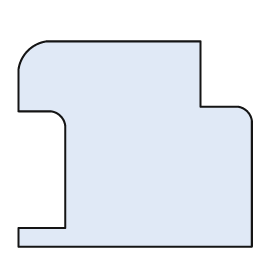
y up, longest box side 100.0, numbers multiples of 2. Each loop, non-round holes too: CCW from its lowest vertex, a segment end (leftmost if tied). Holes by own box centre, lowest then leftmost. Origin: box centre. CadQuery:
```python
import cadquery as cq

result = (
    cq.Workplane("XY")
    .moveTo(-50.0, -44.0)
    .lineTo(50.0, -44.0)
    .lineTo(50.0, 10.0)
    .threePointArc((48.0, 14.0), (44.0, 16.0))
    .lineTo(28.0, 16.0)
    .lineTo(28.0, 44.0)
    .lineTo(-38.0, 44.0)
    .threePointArc((-46.0, 40.0), (-50.0, 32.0))
    .lineTo(-50.0, 14.0)
    .lineTo(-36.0, 14.0)
    .threePointArc((-32.0, 12.0), (-30.0, 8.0))
    .lineTo(-30.0, -36.0)
    .lineTo(-50.0, -36.0)
    .close()
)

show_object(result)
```